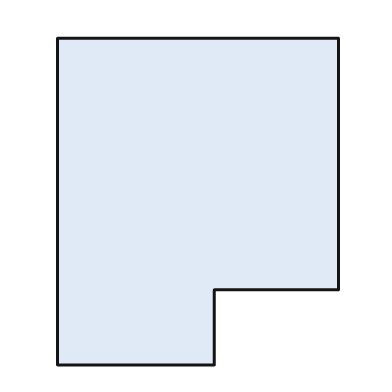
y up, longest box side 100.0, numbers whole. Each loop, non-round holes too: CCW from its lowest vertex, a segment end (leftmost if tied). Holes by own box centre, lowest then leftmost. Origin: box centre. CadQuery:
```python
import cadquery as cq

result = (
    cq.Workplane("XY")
    .moveTo(-43.0, -50.0)
    .lineTo(5.0, -50.0)
    .lineTo(5.0, -27.0)
    .lineTo(43.0, -27.0)
    .lineTo(43.0, 50.0)
    .lineTo(-43.0, 50.0)
    .close()
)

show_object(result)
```